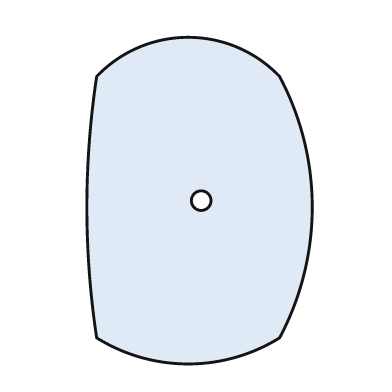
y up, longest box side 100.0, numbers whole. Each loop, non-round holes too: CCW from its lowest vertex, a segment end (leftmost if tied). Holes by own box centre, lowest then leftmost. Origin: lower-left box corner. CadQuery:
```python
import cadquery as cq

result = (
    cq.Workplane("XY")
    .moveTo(3.0, 8.0)
    .threePointArc((31.0, 0.0), (59.0, 8.0))
    .threePointArc((69.0, 48.0), (59.0, 88.0))
    .threePointArc((31.0, 100.0), (3.0, 88.0))
    .threePointArc((0.0, 48.0), (3.0, 8.0))
    .close()
    .moveTo(35.0, 50.0)
    .circle(3.0)
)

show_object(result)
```